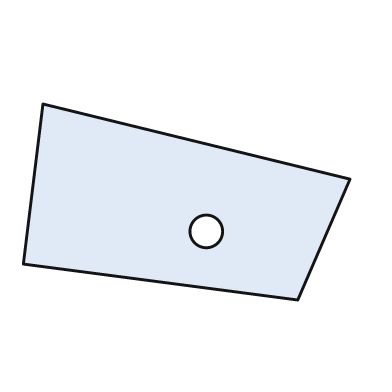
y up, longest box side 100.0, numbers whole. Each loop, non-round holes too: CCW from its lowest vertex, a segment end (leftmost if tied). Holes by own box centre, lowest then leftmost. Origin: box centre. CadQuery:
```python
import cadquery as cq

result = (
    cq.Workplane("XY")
    .moveTo(34.0, -30.0)
    .lineTo(50.0, 7.0)
    .lineTo(-44.0, 30.0)
    .lineTo(-50.0, -19.0)
    .close()
    .moveTo(6.0, -9.0)
    .circle(5.0)
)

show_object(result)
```